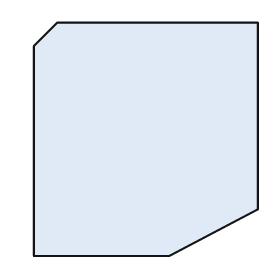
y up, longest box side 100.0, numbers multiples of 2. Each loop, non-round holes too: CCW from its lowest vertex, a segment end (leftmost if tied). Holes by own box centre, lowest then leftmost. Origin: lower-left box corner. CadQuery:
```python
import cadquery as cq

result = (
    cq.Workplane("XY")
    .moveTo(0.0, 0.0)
    .lineTo(58.0, 0.0)
    .lineTo(96.0, 20.0)
    .lineTo(96.0, 100.0)
    .lineTo(10.0, 100.0)
    .lineTo(0.0, 90.0)
    .close()
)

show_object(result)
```